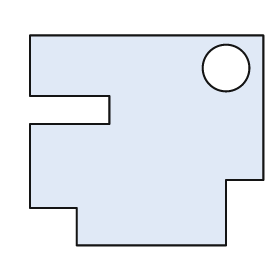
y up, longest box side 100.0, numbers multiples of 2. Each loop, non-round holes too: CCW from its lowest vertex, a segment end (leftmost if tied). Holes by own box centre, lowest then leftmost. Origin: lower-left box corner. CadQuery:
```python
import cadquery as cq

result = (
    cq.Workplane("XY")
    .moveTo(20.0, 0.0)
    .lineTo(84.0, 0.0)
    .lineTo(84.0, 28.0)
    .lineTo(100.0, 28.0)
    .lineTo(100.0, 90.0)
    .lineTo(0.0, 90.0)
    .lineTo(0.0, 64.0)
    .lineTo(34.0, 64.0)
    .lineTo(34.0, 52.0)
    .lineTo(0.0, 52.0)
    .lineTo(0.0, 16.0)
    .lineTo(20.0, 16.0)
    .close()
    .moveTo(84.0, 76.0)
    .circle(10.0)
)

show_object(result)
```